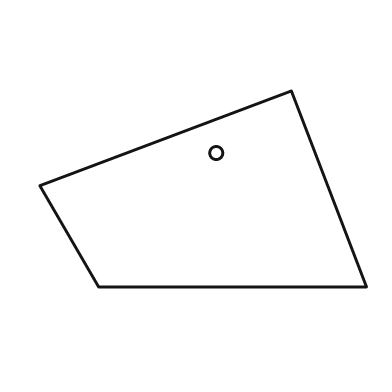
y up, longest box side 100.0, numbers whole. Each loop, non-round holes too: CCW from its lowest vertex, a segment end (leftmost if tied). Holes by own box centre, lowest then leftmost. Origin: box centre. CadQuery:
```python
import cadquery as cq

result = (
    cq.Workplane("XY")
    .moveTo(-32.0, -30.0)
    .lineTo(50.0, -30.0)
    .lineTo(27.0, 30.0)
    .lineTo(-50.0, 1.0)
    .close()
    .moveTo(4.0, 11.0)
    .circle(2.0)
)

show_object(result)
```